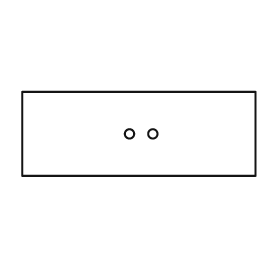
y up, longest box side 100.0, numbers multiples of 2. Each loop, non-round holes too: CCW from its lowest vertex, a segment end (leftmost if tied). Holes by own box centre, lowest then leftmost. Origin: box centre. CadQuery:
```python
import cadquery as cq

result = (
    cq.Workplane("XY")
    .moveTo(-50.0, -18.0)
    .lineTo(50.0, -18.0)
    .lineTo(50.0, 18.0)
    .lineTo(-50.0, 18.0)
    .close()
    .moveTo(-4.0, 0.0)
    .circle(2.0)
    .moveTo(6.0, 0.0)
    .circle(2.0)
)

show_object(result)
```